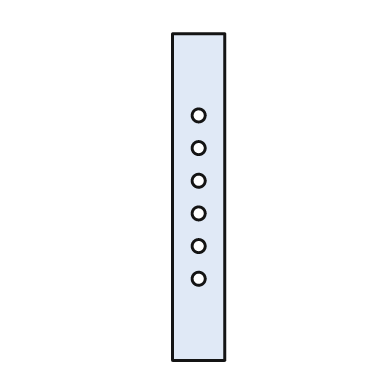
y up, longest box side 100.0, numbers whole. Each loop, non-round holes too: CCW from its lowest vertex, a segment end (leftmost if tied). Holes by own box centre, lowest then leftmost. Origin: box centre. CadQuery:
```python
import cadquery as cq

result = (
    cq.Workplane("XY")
    .moveTo(-8.0, -50.0)
    .lineTo(8.0, -50.0)
    .lineTo(8.0, 50.0)
    .lineTo(-8.0, 50.0)
    .close()
    .moveTo(0.0, -25.0)
    .circle(2.0)
    .moveTo(0.0, -15.0)
    .circle(2.0)
    .moveTo(0.0, -5.0)
    .circle(2.0)
    .moveTo(0.0, 5.0)
    .circle(2.0)
    .moveTo(0.0, 15.0)
    .circle(2.0)
    .moveTo(0.0, 25.0)
    .circle(2.0)
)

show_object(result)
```